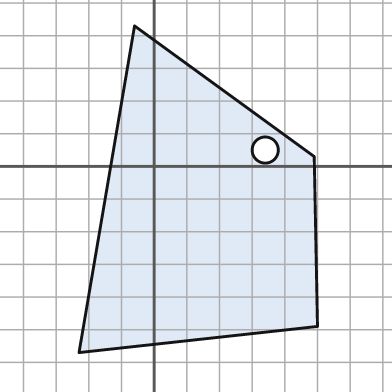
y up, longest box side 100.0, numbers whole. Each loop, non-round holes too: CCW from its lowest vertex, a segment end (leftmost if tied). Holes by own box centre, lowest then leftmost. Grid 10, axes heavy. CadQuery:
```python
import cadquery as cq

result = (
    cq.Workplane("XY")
    .moveTo(-23.0, -57.0)
    .lineTo(50.0, -49.0)
    .lineTo(49.0, 3.0)
    .lineTo(-6.0, 43.0)
    .close()
    .moveTo(34.0, 5.0)
    .circle(4.0)
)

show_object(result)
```